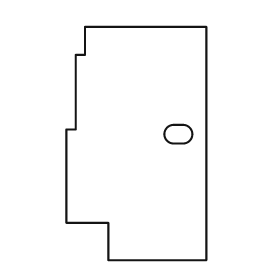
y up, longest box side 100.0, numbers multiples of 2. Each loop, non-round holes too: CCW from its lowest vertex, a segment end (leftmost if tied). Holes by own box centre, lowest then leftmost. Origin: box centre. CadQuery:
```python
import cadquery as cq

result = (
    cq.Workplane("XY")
    .moveTo(-12.0, -50.0)
    .lineTo(30.0, -50.0)
    .lineTo(30.0, 50.0)
    .lineTo(-22.0, 50.0)
    .lineTo(-22.0, 38.0)
    .lineTo(-26.0, 38.0)
    .lineTo(-26.0, 6.0)
    .lineTo(-30.0, 6.0)
    .lineTo(-30.0, -34.0)
    .lineTo(-12.0, -34.0)
    .close()
    .moveTo(16.0, 0.0)
    .lineTo(20.0, 0.0)
    .threePointArc((24.0, 4.0), (20.0, 8.0))
    .lineTo(16.0, 8.0)
    .threePointArc((12.0, 4.0), (16.0, 0.0))
    .close()
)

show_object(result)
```